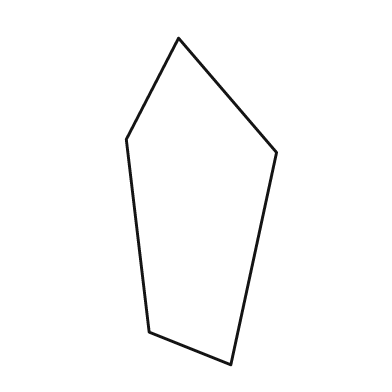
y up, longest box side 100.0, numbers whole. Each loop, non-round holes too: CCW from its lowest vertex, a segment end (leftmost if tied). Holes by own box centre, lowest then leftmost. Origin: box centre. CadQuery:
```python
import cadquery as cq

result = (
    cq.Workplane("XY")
    .moveTo(9.0, -50.0)
    .lineTo(23.0, 15.0)
    .lineTo(-7.0, 50.0)
    .lineTo(-23.0, 19.0)
    .lineTo(-16.0, -40.0)
    .close()
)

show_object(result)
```